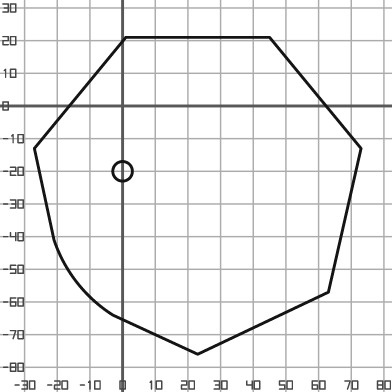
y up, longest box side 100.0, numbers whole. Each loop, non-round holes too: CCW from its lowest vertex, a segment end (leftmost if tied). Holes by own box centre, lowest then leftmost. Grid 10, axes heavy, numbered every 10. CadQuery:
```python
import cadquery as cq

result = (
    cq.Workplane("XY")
    .moveTo(23.0, -76.0)
    .lineTo(63.0, -57.0)
    .lineTo(73.0, -13.0)
    .lineTo(45.0, 21.0)
    .lineTo(1.0, 21.0)
    .lineTo(-27.0, -13.0)
    .lineTo(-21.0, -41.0)
    .threePointArc((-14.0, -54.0), (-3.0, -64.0))
    .close()
    .moveTo(0.0, -20.0)
    .circle(3.0)
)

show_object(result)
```